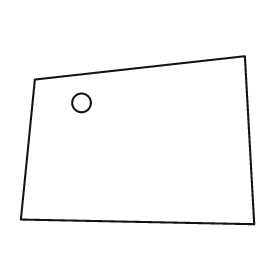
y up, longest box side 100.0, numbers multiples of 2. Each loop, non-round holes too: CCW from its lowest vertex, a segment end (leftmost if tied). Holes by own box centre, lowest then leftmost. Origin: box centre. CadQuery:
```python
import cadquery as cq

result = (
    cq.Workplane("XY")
    .moveTo(50.0, -36.0)
    .lineTo(46.0, 36.0)
    .lineTo(-44.0, 26.0)
    .lineTo(-50.0, -34.0)
    .close()
    .moveTo(-24.0, 16.0)
    .circle(4.0)
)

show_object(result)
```